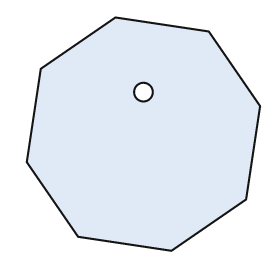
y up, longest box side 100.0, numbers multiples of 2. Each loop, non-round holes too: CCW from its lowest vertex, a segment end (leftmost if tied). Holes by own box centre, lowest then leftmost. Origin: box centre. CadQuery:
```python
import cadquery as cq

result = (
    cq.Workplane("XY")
    .moveTo(12.0, -50.0)
    .lineTo(44.0, -28.0)
    .lineTo(50.0, 12.0)
    .lineTo(28.0, 44.0)
    .lineTo(-12.0, 50.0)
    .lineTo(-44.0, 28.0)
    .lineTo(-50.0, -12.0)
    .lineTo(-28.0, -44.0)
    .close()
    .moveTo(0.0, 18.0)
    .circle(4.0)
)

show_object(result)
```